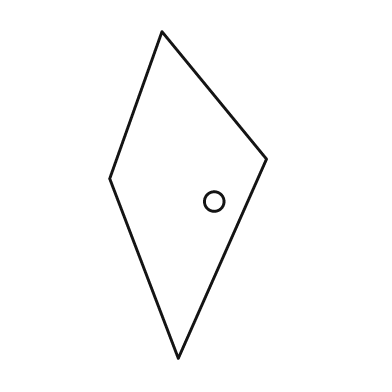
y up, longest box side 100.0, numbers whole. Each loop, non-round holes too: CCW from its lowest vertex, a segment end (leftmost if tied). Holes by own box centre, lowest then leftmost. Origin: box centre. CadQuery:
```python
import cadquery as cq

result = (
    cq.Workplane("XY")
    .moveTo(-3.0, -50.0)
    .lineTo(24.0, 11.0)
    .lineTo(-8.0, 50.0)
    .lineTo(-24.0, 5.0)
    .close()
    .moveTo(8.0, -2.0)
    .circle(3.0)
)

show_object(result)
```